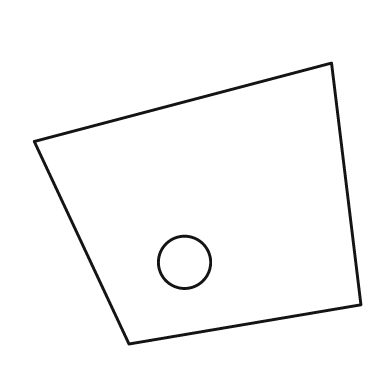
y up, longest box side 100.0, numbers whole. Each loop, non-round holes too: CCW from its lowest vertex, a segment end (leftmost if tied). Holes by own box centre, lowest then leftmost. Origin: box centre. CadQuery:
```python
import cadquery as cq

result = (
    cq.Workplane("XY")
    .moveTo(-21.0, -43.0)
    .lineTo(50.0, -31.0)
    .lineTo(41.0, 43.0)
    .lineTo(-50.0, 19.0)
    .close()
    .moveTo(-4.0, -18.0)
    .circle(8.0)
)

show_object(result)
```